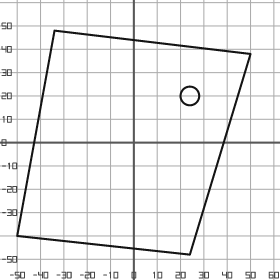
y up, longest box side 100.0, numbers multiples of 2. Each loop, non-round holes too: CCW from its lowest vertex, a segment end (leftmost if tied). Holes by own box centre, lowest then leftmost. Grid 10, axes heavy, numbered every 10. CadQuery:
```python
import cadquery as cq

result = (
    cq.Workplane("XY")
    .moveTo(24.0, -48.0)
    .lineTo(50.0, 38.0)
    .lineTo(-34.0, 48.0)
    .lineTo(-50.0, -40.0)
    .close()
    .moveTo(24.0, 20.0)
    .circle(4.0)
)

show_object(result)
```